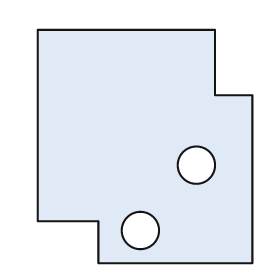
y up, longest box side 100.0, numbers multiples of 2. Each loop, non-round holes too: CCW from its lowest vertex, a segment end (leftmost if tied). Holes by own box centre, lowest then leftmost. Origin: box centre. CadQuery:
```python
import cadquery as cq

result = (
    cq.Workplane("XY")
    .moveTo(-20.0, -50.0)
    .lineTo(46.0, -50.0)
    .lineTo(46.0, 22.0)
    .lineTo(30.0, 22.0)
    .lineTo(30.0, 50.0)
    .lineTo(-46.0, 50.0)
    .lineTo(-46.0, -32.0)
    .lineTo(-20.0, -32.0)
    .close()
    .moveTo(-2.0, -36.0)
    .circle(8.0)
    .moveTo(22.0, -8.0)
    .circle(8.0)
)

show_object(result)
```